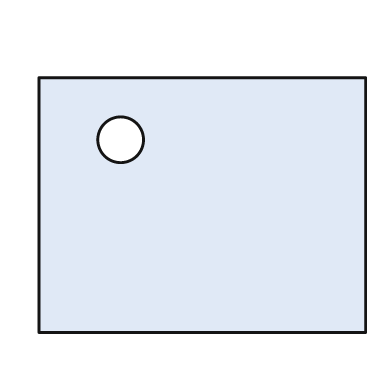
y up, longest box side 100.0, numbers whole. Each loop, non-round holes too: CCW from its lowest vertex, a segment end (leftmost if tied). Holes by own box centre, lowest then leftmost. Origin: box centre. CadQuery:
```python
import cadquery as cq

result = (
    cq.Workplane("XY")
    .moveTo(-50.0, -39.0)
    .lineTo(50.0, -39.0)
    .lineTo(50.0, 39.0)
    .lineTo(-50.0, 39.0)
    .close()
    .moveTo(-25.0, 20.0)
    .circle(7.0)
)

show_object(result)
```